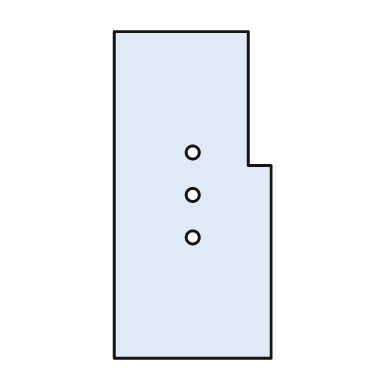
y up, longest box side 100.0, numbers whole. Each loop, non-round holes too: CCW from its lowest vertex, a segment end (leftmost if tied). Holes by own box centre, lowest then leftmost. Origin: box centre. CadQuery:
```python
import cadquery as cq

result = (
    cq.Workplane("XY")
    .moveTo(-24.0, -50.0)
    .lineTo(24.0, -50.0)
    .lineTo(24.0, 9.0)
    .lineTo(17.0, 9.0)
    .lineTo(17.0, 50.0)
    .lineTo(-24.0, 50.0)
    .close()
    .moveTo(0.0, -13.0)
    .circle(2.0)
    .moveTo(0.0, 0.0)
    .circle(2.0)
    .moveTo(0.0, 13.0)
    .circle(2.0)
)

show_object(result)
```